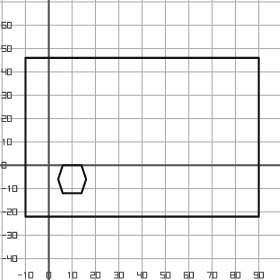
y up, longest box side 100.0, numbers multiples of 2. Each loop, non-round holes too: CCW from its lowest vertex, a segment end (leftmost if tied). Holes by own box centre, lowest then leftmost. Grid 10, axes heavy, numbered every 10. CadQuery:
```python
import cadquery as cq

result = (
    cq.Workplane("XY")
    .moveTo(-10.0, -22.0)
    .lineTo(90.0, -22.0)
    .lineTo(90.0, 46.0)
    .lineTo(-10.0, 46.0)
    .close()
    .moveTo(6.0, -12.0)
    .lineTo(14.0, -12.0)
    .lineTo(16.0, -6.0)
    .lineTo(14.0, 0.0)
    .lineTo(6.0, 0.0)
    .lineTo(4.0, -6.0)
    .close()
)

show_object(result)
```